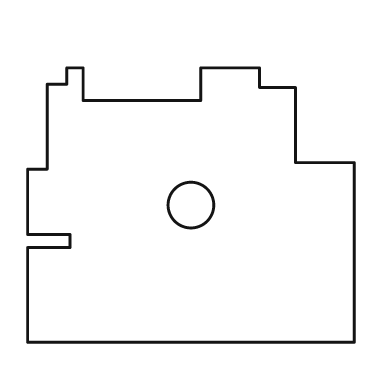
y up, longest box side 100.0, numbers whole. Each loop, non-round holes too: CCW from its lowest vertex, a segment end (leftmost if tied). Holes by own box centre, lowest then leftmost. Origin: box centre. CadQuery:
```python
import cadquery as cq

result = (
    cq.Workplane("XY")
    .moveTo(-50.0, -42.0)
    .lineTo(50.0, -42.0)
    .lineTo(50.0, 13.0)
    .lineTo(32.0, 13.0)
    .lineTo(32.0, 36.0)
    .lineTo(21.0, 36.0)
    .lineTo(21.0, 42.0)
    .lineTo(3.0, 42.0)
    .lineTo(3.0, 32.0)
    .lineTo(-33.0, 32.0)
    .lineTo(-33.0, 42.0)
    .lineTo(-38.0, 42.0)
    .lineTo(-38.0, 37.0)
    .lineTo(-44.0, 37.0)
    .lineTo(-44.0, 11.0)
    .lineTo(-50.0, 11.0)
    .lineTo(-50.0, -9.0)
    .lineTo(-37.0, -9.0)
    .lineTo(-37.0, -13.0)
    .lineTo(-50.0, -13.0)
    .close()
    .moveTo(0.0, 0.0)
    .circle(7.0)
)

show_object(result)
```